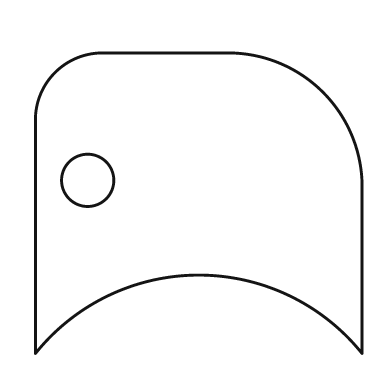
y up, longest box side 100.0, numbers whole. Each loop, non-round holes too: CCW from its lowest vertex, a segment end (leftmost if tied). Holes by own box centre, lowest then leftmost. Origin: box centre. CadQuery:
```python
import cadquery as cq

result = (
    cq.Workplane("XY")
    .moveTo(-50.0, -46.0)
    .threePointArc((0.0, -22.0), (50.0, -46.0))
    .lineTo(50.0, 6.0)
    .threePointArc((38.0, 34.0), (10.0, 46.0))
    .lineTo(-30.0, 46.0)
    .threePointArc((-44.0, 40.0), (-50.0, 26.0))
    .close()
    .moveTo(-34.0, 7.0)
    .circle(8.0)
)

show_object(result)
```